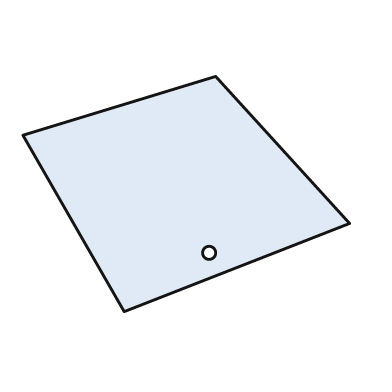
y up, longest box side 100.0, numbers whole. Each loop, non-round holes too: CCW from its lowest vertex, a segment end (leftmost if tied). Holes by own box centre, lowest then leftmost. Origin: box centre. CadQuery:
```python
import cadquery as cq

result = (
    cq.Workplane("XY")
    .moveTo(-19.0, -36.0)
    .lineTo(50.0, -9.0)
    .lineTo(9.0, 36.0)
    .lineTo(-50.0, 18.0)
    .close()
    .moveTo(7.0, -18.0)
    .circle(2.0)
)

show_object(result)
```